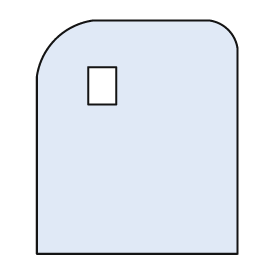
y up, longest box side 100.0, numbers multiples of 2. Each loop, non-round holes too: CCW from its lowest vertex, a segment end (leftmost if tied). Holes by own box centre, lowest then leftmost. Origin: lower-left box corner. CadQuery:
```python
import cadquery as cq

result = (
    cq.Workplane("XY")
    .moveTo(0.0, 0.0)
    .lineTo(86.0, 0.0)
    .lineTo(86.0, 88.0)
    .threePointArc((82.0, 96.0), (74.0, 100.0))
    .lineTo(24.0, 100.0)
    .threePointArc((8.0, 92.0), (0.0, 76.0))
    .close()
    .moveTo(22.0, 64.0)
    .lineTo(34.0, 64.0)
    .lineTo(34.0, 80.0)
    .lineTo(22.0, 80.0)
    .close()
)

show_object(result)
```